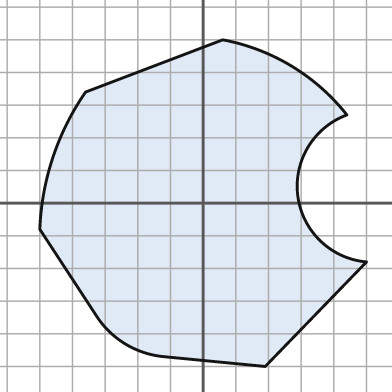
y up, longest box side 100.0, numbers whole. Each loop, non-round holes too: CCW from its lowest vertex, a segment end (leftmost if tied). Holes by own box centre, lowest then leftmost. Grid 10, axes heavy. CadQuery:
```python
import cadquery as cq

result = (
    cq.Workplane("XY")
    .moveTo(19.0, -50.0)
    .lineTo(50.0, -18.0)
    .threePointArc((29.0, 2.0), (44.0, 27.0))
    .threePointArc((27.0, 42.0), (6.0, 50.0))
    .lineTo(-36.0, 34.0)
    .threePointArc((-46.0, 14.0), (-50.0, -8.0))
    .lineTo(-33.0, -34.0)
    .threePointArc((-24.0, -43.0), (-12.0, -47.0))
    .close()
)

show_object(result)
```